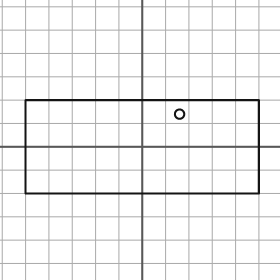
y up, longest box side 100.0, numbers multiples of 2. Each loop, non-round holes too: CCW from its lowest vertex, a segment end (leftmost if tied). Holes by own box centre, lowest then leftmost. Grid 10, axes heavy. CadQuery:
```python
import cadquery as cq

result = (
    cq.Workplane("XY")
    .moveTo(-50.0, -20.0)
    .lineTo(50.0, -20.0)
    .lineTo(50.0, 20.0)
    .lineTo(-50.0, 20.0)
    .close()
    .moveTo(16.0, 14.0)
    .circle(2.0)
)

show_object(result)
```